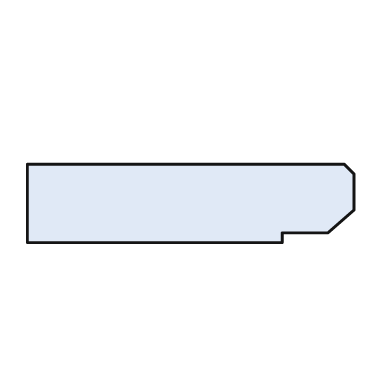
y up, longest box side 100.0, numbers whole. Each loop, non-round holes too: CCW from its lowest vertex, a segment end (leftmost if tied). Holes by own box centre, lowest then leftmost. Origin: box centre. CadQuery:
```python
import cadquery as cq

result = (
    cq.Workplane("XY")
    .moveTo(-50.0, -12.0)
    .lineTo(28.0, -12.0)
    .lineTo(28.0, -9.0)
    .lineTo(42.0, -9.0)
    .lineTo(50.0, -2.0)
    .lineTo(50.0, 9.0)
    .lineTo(47.0, 12.0)
    .lineTo(-50.0, 12.0)
    .close()
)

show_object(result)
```